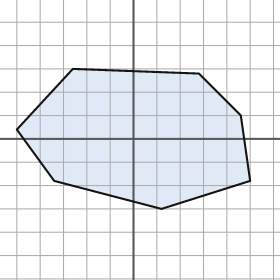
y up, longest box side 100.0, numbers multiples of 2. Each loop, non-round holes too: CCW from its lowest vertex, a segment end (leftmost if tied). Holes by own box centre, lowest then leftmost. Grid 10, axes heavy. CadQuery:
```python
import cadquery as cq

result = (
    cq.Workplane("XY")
    .moveTo(12.0, -30.0)
    .lineTo(50.0, -18.0)
    .lineTo(46.0, 10.0)
    .lineTo(28.0, 28.0)
    .lineTo(-26.0, 30.0)
    .lineTo(-50.0, 4.0)
    .lineTo(-34.0, -18.0)
    .close()
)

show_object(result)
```